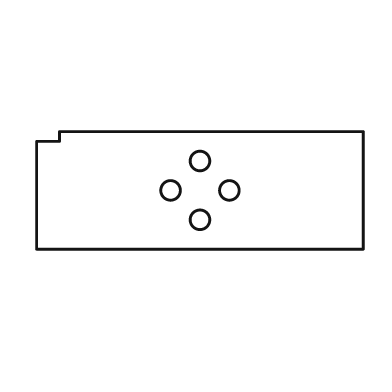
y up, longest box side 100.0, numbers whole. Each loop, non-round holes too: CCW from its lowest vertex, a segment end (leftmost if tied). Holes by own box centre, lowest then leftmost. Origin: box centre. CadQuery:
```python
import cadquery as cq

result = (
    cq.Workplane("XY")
    .moveTo(-50.0, -18.0)
    .lineTo(50.0, -18.0)
    .lineTo(50.0, 18.0)
    .lineTo(-43.0, 18.0)
    .lineTo(-43.0, 15.0)
    .lineTo(-50.0, 15.0)
    .close()
    .moveTo(0.0, -9.0)
    .circle(3.0)
    .moveTo(-9.0, 0.0)
    .circle(3.0)
    .moveTo(9.0, 0.0)
    .circle(3.0)
    .moveTo(0.0, 9.0)
    .circle(3.0)
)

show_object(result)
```